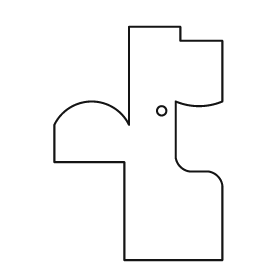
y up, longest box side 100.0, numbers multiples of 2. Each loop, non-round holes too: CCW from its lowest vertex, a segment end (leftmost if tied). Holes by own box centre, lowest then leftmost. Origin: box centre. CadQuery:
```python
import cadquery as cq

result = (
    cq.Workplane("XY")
    .moveTo(-6.0, -50.0)
    .lineTo(36.0, -50.0)
    .lineTo(36.0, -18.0)
    .threePointArc((34.0, -14.0), (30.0, -12.0))
    .lineTo(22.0, -12.0)
    .threePointArc((18.0, -10.0), (16.0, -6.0))
    .lineTo(16.0, 18.0)
    .threePointArc((26.0, 16.0), (36.0, 18.0))
    .lineTo(36.0, 44.0)
    .lineTo(18.0, 44.0)
    .lineTo(18.0, 50.0)
    .lineTo(-4.0, 50.0)
    .lineTo(-4.0, 8.0)
    .threePointArc((-20.0, 18.0), (-36.0, 8.0))
    .lineTo(-36.0, -8.0)
    .lineTo(-6.0, -8.0)
    .close()
    .moveTo(10.0, 14.0)
    .circle(2.0)
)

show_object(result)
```